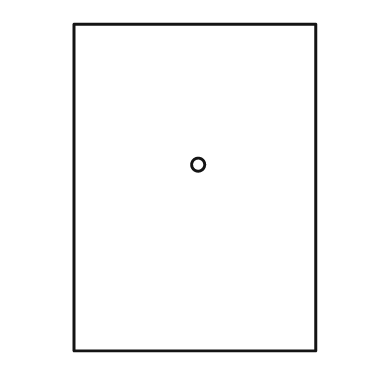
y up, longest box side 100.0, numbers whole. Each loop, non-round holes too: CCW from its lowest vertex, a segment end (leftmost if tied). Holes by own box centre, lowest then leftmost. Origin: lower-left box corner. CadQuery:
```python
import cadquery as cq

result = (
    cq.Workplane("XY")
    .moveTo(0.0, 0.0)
    .lineTo(74.0, 0.0)
    .lineTo(74.0, 100.0)
    .lineTo(0.0, 100.0)
    .close()
    .moveTo(38.0, 57.0)
    .circle(2.0)
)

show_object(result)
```